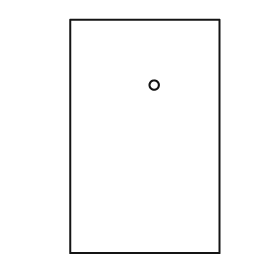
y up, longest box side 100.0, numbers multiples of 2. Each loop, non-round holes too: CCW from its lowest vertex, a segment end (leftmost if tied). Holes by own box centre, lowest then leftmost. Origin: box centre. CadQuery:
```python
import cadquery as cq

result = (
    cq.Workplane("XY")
    .moveTo(-32.0, -50.0)
    .lineTo(32.0, -50.0)
    .lineTo(32.0, 50.0)
    .lineTo(-32.0, 50.0)
    .close()
    .moveTo(4.0, 22.0)
    .circle(2.0)
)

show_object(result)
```